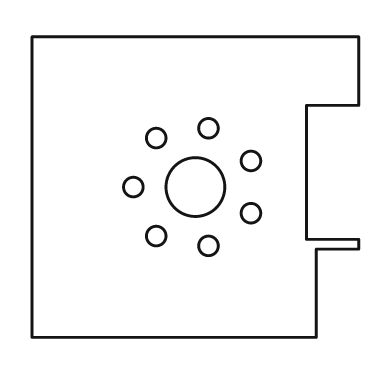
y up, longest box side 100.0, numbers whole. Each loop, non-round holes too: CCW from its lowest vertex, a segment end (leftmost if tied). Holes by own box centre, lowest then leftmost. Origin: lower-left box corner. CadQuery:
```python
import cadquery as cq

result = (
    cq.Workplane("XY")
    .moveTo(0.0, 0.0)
    .lineTo(87.0, 0.0)
    .lineTo(87.0, 27.0)
    .lineTo(100.0, 27.0)
    .lineTo(100.0, 30.0)
    .lineTo(84.0, 30.0)
    .lineTo(84.0, 71.0)
    .lineTo(100.0, 71.0)
    .lineTo(100.0, 92.0)
    .lineTo(0.0, 92.0)
    .close()
    .moveTo(54.0, 28.0)
    .circle(3.0)
    .moveTo(38.0, 31.0)
    .circle(3.0)
    .moveTo(67.0, 38.0)
    .circle(3.0)
    .moveTo(31.0, 46.0)
    .circle(3.0)
    .moveTo(50.0, 46.0)
    .circle(9.0)
    .moveTo(67.0, 54.0)
    .circle(3.0)
    .moveTo(38.0, 61.0)
    .circle(3.0)
    .moveTo(54.0, 64.0)
    .circle(3.0)
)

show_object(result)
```